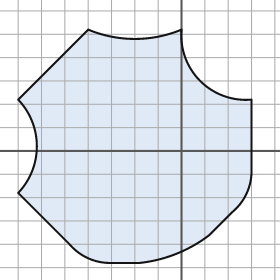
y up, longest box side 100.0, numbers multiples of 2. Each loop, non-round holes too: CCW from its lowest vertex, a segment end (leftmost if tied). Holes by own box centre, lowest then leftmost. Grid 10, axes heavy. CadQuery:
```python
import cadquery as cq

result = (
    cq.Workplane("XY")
    .moveTo(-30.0, -48.0)
    .lineTo(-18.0, -48.0)
    .threePointArc((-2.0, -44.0), (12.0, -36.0))
    .lineTo(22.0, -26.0)
    .threePointArc((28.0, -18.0), (30.0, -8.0))
    .lineTo(30.0, 22.0)
    .threePointArc((8.0, 30.0), (0.0, 52.0))
    .threePointArc((-20.0, 48.0), (-40.0, 52.0))
    .lineTo(-70.0, 22.0)
    .threePointArc((-62.0, 2.0), (-70.0, -18.0))
    .lineTo(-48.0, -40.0)
    .threePointArc((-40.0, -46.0), (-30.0, -48.0))
    .close()
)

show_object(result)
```